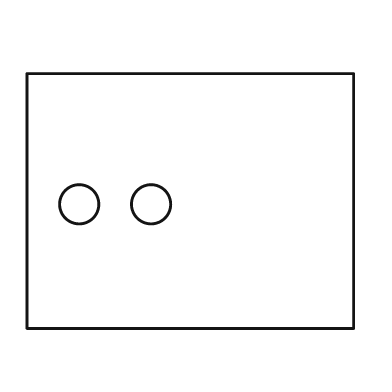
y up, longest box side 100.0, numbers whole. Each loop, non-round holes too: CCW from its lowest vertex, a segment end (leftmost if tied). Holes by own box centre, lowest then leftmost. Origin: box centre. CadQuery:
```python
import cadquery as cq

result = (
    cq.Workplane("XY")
    .moveTo(-50.0, -39.0)
    .lineTo(50.0, -39.0)
    .lineTo(50.0, 39.0)
    .lineTo(-50.0, 39.0)
    .close()
    .moveTo(-34.0, -1.0)
    .circle(6.0)
    .moveTo(-12.0, -1.0)
    .circle(6.0)
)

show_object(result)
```